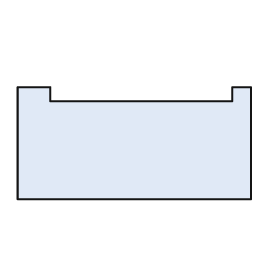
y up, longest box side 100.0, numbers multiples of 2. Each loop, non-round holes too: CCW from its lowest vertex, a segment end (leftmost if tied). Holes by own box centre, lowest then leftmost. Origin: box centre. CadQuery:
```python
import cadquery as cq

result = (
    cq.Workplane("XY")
    .moveTo(-50.0, -24.0)
    .lineTo(50.0, -24.0)
    .lineTo(50.0, 24.0)
    .lineTo(42.0, 24.0)
    .lineTo(42.0, 18.0)
    .lineTo(-36.0, 18.0)
    .lineTo(-36.0, 24.0)
    .lineTo(-50.0, 24.0)
    .close()
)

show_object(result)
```